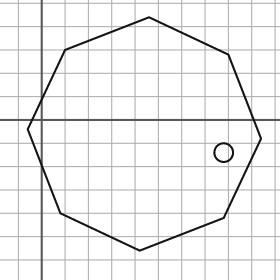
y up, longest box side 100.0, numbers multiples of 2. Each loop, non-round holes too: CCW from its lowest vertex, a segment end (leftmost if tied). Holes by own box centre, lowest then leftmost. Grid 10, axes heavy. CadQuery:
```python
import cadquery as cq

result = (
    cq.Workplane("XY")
    .moveTo(42.0, -56.0)
    .lineTo(78.0, -42.0)
    .lineTo(94.0, -8.0)
    .lineTo(80.0, 28.0)
    .lineTo(46.0, 44.0)
    .lineTo(10.0, 30.0)
    .lineTo(-6.0, -4.0)
    .lineTo(8.0, -40.0)
    .close()
    .moveTo(78.0, -14.0)
    .circle(4.0)
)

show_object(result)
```